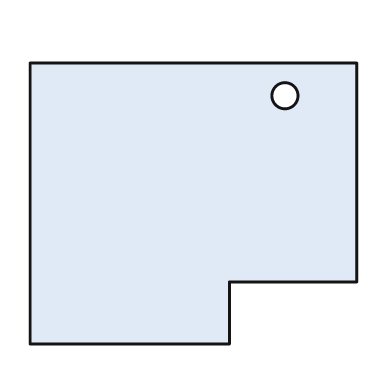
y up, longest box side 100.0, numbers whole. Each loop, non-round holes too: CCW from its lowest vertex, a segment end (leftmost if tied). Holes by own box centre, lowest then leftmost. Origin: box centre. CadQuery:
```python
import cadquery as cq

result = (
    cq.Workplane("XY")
    .moveTo(-50.0, -43.0)
    .lineTo(11.0, -43.0)
    .lineTo(11.0, -24.0)
    .lineTo(50.0, -24.0)
    .lineTo(50.0, 43.0)
    .lineTo(-50.0, 43.0)
    .close()
    .moveTo(28.0, 33.0)
    .circle(4.0)
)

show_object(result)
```